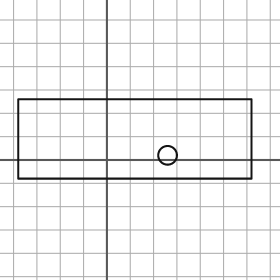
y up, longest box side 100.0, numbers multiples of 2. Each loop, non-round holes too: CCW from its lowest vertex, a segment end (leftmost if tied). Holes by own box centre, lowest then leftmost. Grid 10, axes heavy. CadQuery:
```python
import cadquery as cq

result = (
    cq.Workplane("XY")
    .moveTo(-38.0, -8.0)
    .lineTo(62.0, -8.0)
    .lineTo(62.0, 26.0)
    .lineTo(-38.0, 26.0)
    .close()
    .moveTo(26.0, 2.0)
    .circle(4.0)
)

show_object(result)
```